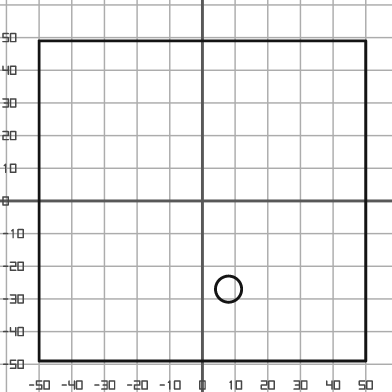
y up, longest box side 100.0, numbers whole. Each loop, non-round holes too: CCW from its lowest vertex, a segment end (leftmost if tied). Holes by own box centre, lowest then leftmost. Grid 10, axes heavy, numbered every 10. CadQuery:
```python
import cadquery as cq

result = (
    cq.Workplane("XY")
    .moveTo(-50.0, -49.0)
    .lineTo(50.0, -49.0)
    .lineTo(50.0, 49.0)
    .lineTo(-50.0, 49.0)
    .close()
    .moveTo(8.0, -27.0)
    .circle(4.0)
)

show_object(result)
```